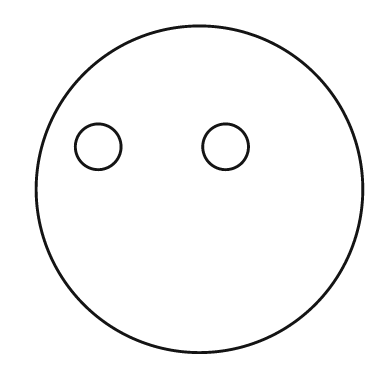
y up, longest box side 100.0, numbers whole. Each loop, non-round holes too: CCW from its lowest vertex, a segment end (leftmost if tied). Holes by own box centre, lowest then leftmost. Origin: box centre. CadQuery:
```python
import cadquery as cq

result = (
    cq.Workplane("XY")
    .moveTo(0.0, 0.0)
    .circle(50.0)
    .moveTo(-31.0, 13.0)
    .circle(7.0)
    .moveTo(8.0, 13.0)
    .circle(7.0)
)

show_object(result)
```